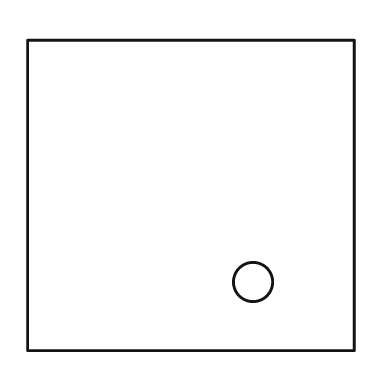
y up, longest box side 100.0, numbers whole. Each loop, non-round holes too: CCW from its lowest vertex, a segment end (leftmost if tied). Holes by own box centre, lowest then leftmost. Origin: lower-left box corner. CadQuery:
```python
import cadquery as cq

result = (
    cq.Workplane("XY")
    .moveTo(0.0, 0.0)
    .lineTo(100.0, 0.0)
    .lineTo(100.0, 95.0)
    .lineTo(0.0, 95.0)
    .close()
    .moveTo(69.0, 21.0)
    .circle(6.0)
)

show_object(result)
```